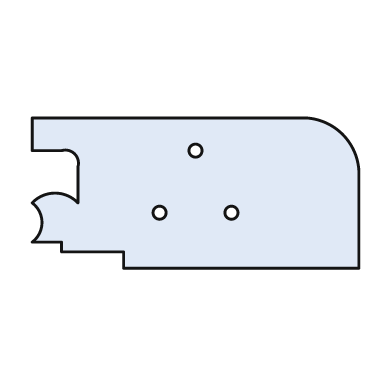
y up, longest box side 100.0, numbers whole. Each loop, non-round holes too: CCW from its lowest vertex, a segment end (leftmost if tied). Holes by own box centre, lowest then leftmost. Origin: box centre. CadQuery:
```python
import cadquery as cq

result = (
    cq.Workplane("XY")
    .moveTo(-22.0, -23.0)
    .lineTo(50.0, -23.0)
    .lineTo(50.0, 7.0)
    .threePointArc((45.0, 18.0), (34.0, 23.0))
    .lineTo(-50.0, 23.0)
    .lineTo(-50.0, 13.0)
    .lineTo(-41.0, 13.0)
    .threePointArc((-37.0, 12.0), (-36.0, 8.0))
    .lineTo(-36.0, -3.0)
    .threePointArc((-43.0, 0.0), (-50.0, -3.0))
    .threePointArc((-47.0, -9.0), (-50.0, -15.0))
    .lineTo(-41.0, -15.0)
    .lineTo(-41.0, -18.0)
    .lineTo(-22.0, -18.0)
    .close()
    .moveTo(-11.0, -6.0)
    .circle(2.0)
    .moveTo(11.0, -6.0)
    .circle(2.0)
    .moveTo(0.0, 13.0)
    .circle(2.0)
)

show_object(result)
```